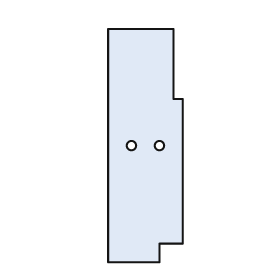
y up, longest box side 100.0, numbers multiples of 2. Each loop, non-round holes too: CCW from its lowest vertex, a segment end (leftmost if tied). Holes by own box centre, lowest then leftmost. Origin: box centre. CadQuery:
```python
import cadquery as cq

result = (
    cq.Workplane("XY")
    .moveTo(-16.0, -50.0)
    .lineTo(6.0, -50.0)
    .lineTo(6.0, -42.0)
    .lineTo(16.0, -42.0)
    .lineTo(16.0, 20.0)
    .lineTo(12.0, 20.0)
    .lineTo(12.0, 50.0)
    .lineTo(-16.0, 50.0)
    .close()
    .moveTo(-6.0, 0.0)
    .circle(2.0)
    .moveTo(6.0, 0.0)
    .circle(2.0)
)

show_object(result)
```